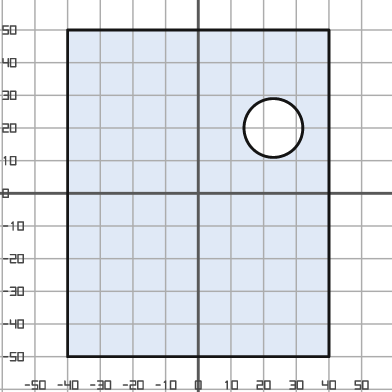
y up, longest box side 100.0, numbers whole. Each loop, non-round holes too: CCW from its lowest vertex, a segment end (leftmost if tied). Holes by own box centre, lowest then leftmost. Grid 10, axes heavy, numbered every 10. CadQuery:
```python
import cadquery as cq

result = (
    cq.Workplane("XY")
    .moveTo(-40.0, -50.0)
    .lineTo(40.0, -50.0)
    .lineTo(40.0, 50.0)
    .lineTo(-40.0, 50.0)
    .close()
    .moveTo(23.0, 20.0)
    .circle(9.0)
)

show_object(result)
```